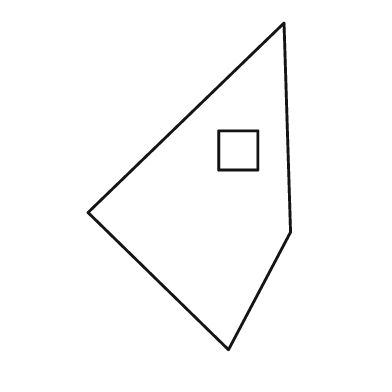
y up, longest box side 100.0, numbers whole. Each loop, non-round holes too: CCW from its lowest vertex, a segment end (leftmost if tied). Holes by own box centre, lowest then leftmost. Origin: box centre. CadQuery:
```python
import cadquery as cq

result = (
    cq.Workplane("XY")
    .moveTo(12.0, -50.0)
    .lineTo(31.0, -14.0)
    .lineTo(29.0, 50.0)
    .lineTo(-31.0, -8.0)
    .close()
    .moveTo(9.0, 5.0)
    .lineTo(21.0, 5.0)
    .lineTo(21.0, 17.0)
    .lineTo(9.0, 17.0)
    .close()
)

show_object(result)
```